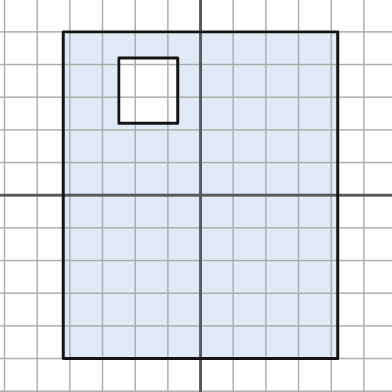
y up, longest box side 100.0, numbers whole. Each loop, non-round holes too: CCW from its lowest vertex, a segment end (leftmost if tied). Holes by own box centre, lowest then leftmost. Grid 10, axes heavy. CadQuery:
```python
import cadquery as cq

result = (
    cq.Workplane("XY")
    .moveTo(-42.0, -50.0)
    .lineTo(42.0, -50.0)
    .lineTo(42.0, 50.0)
    .lineTo(-42.0, 50.0)
    .close()
    .moveTo(-25.0, 22.0)
    .lineTo(-7.0, 22.0)
    .lineTo(-7.0, 42.0)
    .lineTo(-25.0, 42.0)
    .close()
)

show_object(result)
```